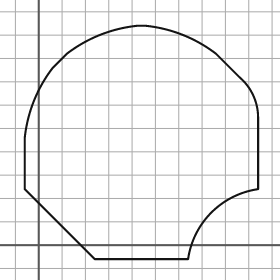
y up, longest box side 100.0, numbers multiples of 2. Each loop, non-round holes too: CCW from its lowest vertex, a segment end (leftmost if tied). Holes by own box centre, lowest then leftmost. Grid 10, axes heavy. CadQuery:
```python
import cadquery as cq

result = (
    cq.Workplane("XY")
    .moveTo(24.0, -6.0)
    .lineTo(64.0, -6.0)
    .threePointArc((74.0, 14.0), (94.0, 24.0))
    .lineTo(94.0, 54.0)
    .threePointArc((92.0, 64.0), (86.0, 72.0))
    .lineTo(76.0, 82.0)
    .threePointArc((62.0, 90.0), (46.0, 94.0))
    .lineTo(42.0, 94.0)
    .threePointArc((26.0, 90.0), (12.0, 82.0))
    .lineTo(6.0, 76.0)
    .threePointArc((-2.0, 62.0), (-6.0, 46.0))
    .lineTo(-6.0, 24.0)
    .close()
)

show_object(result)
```